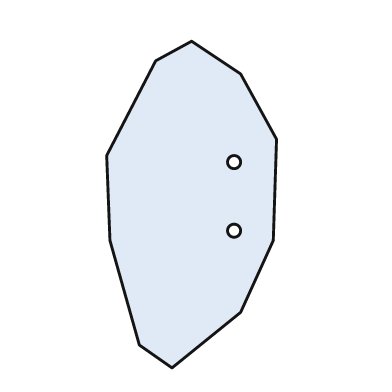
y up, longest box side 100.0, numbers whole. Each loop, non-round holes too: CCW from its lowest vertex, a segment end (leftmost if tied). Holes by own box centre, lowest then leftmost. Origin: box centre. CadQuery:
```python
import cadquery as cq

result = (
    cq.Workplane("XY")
    .moveTo(-6.0, -50.0)
    .lineTo(15.0, -33.0)
    .lineTo(25.0, -11.0)
    .lineTo(26.0, 20.0)
    .lineTo(15.0, 40.0)
    .lineTo(0.0, 50.0)
    .lineTo(-11.0, 44.0)
    .lineTo(-26.0, 15.0)
    .lineTo(-25.0, -11.0)
    .lineTo(-16.0, -43.0)
    .close()
    .moveTo(13.0, -8.0)
    .circle(2.0)
    .moveTo(13.0, 13.0)
    .circle(2.0)
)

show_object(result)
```